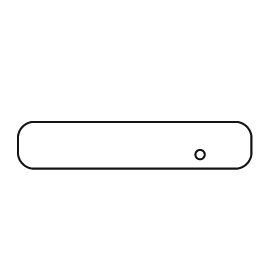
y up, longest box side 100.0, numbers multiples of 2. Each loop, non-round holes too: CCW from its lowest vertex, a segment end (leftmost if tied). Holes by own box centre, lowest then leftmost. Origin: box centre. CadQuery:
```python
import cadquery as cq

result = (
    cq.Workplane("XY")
    .moveTo(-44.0, -10.0)
    .lineTo(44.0, -10.0)
    .threePointArc((48.0, -8.0), (50.0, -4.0))
    .lineTo(50.0, 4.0)
    .threePointArc((48.0, 8.0), (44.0, 10.0))
    .lineTo(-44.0, 10.0)
    .threePointArc((-48.0, 8.0), (-50.0, 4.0))
    .lineTo(-50.0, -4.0)
    .threePointArc((-48.0, -8.0), (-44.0, -10.0))
    .close()
    .moveTo(28.0, -4.0)
    .circle(2.0)
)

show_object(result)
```